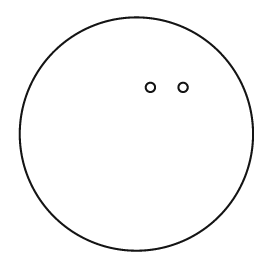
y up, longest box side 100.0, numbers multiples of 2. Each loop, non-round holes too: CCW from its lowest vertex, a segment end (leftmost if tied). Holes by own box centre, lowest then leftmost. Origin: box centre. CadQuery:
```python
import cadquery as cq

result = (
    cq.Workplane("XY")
    .moveTo(0.0, 0.0)
    .circle(50.0)
    .moveTo(6.0, 20.0)
    .circle(2.0)
    .moveTo(20.0, 20.0)
    .circle(2.0)
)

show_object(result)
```